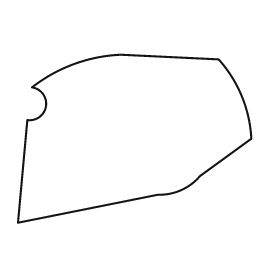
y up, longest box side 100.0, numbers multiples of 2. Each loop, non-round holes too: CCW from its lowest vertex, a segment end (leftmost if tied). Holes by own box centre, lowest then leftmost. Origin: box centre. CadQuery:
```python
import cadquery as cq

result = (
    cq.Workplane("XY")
    .moveTo(-50.0, -36.0)
    .lineTo(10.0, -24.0)
    .threePointArc((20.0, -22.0), (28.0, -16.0))
    .lineTo(50.0, 0.0)
    .threePointArc((46.0, 18.0), (36.0, 34.0))
    .lineTo(-6.0, 36.0)
    .threePointArc((-26.0, 32.0), (-44.0, 22.0))
    .threePointArc((-38.0, 14.0), (-46.0, 8.0))
    .close()
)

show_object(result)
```